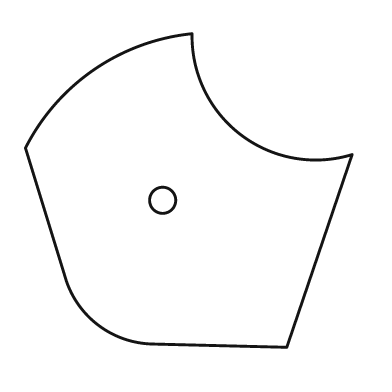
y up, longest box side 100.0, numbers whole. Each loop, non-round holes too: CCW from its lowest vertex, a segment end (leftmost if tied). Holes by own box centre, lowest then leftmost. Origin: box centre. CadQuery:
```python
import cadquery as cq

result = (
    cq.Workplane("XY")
    .moveTo(30.0, -48.0)
    .lineTo(50.0, 11.0)
    .threePointArc((16.0, 17.0), (1.0, 48.0))
    .threePointArc((-29.0, 37.0), (-50.0, 13.0))
    .lineTo(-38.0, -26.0)
    .threePointArc((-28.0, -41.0), (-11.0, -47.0))
    .close()
    .moveTo(-8.0, -3.0)
    .circle(4.0)
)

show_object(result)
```